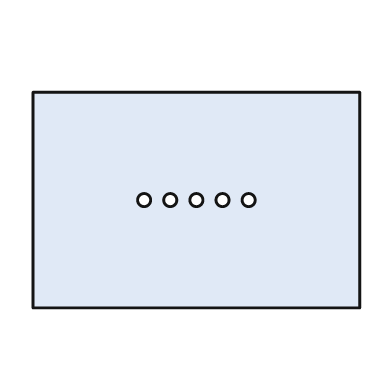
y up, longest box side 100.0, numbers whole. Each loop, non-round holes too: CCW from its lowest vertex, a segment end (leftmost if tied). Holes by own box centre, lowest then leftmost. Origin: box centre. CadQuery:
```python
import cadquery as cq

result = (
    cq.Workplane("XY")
    .moveTo(-50.0, -33.0)
    .lineTo(50.0, -33.0)
    .lineTo(50.0, 33.0)
    .lineTo(-50.0, 33.0)
    .close()
    .moveTo(-16.0, 0.0)
    .circle(2.0)
    .moveTo(-8.0, 0.0)
    .circle(2.0)
    .moveTo(0.0, 0.0)
    .circle(2.0)
    .moveTo(8.0, 0.0)
    .circle(2.0)
    .moveTo(16.0, 0.0)
    .circle(2.0)
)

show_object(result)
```